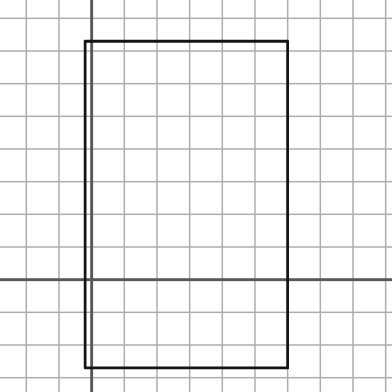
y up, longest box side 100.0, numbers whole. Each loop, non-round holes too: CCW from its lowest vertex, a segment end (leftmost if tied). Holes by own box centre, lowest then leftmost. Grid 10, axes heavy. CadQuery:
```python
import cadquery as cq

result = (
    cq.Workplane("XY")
    .moveTo(-2.0, -27.0)
    .lineTo(60.0, -27.0)
    .lineTo(60.0, 73.0)
    .lineTo(-2.0, 73.0)
    .close()
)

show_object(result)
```